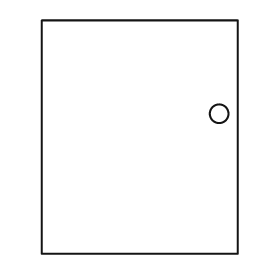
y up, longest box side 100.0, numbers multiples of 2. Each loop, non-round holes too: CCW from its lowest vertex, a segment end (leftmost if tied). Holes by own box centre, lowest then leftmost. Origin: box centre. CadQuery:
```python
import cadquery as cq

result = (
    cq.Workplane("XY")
    .moveTo(-42.0, -50.0)
    .lineTo(42.0, -50.0)
    .lineTo(42.0, 50.0)
    .lineTo(-42.0, 50.0)
    .close()
    .moveTo(34.0, 10.0)
    .circle(4.0)
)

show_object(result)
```